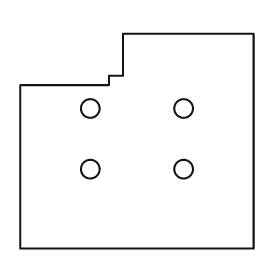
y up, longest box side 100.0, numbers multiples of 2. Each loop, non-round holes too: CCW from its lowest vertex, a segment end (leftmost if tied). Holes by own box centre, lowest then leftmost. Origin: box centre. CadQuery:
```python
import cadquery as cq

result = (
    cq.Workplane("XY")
    .moveTo(-50.0, -46.0)
    .lineTo(50.0, -46.0)
    .lineTo(50.0, 46.0)
    .lineTo(-6.0, 46.0)
    .lineTo(-6.0, 28.0)
    .lineTo(-12.0, 28.0)
    .lineTo(-12.0, 24.0)
    .lineTo(-50.0, 24.0)
    .close()
    .moveTo(-20.0, -12.0)
    .circle(4.0)
    .moveTo(20.0, -12.0)
    .circle(4.0)
    .moveTo(-20.0, 14.0)
    .circle(4.0)
    .moveTo(20.0, 14.0)
    .circle(4.0)
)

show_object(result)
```